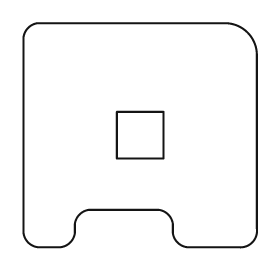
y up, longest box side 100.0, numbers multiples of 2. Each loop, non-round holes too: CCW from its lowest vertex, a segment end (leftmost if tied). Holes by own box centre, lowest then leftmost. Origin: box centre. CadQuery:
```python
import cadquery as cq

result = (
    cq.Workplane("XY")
    .moveTo(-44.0, -48.0)
    .lineTo(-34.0, -48.0)
    .threePointArc((-30.0, -46.0), (-28.0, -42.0))
    .lineTo(-28.0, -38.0)
    .threePointArc((-26.0, -34.0), (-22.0, -32.0))
    .lineTo(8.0, -32.0)
    .threePointArc((12.0, -34.0), (14.0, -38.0))
    .lineTo(14.0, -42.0)
    .threePointArc((16.0, -46.0), (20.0, -48.0))
    .lineTo(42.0, -48.0)
    .threePointArc((48.0, -46.0), (50.0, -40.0))
    .lineTo(50.0, 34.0)
    .threePointArc((46.0, 44.0), (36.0, 48.0))
    .lineTo(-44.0, 48.0)
    .threePointArc((-48.0, 46.0), (-50.0, 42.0))
    .lineTo(-50.0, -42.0)
    .threePointArc((-48.0, -46.0), (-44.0, -48.0))
    .close()
    .moveTo(-10.0, -10.0)
    .lineTo(10.0, -10.0)
    .lineTo(10.0, 10.0)
    .lineTo(-10.0, 10.0)
    .close()
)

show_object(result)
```